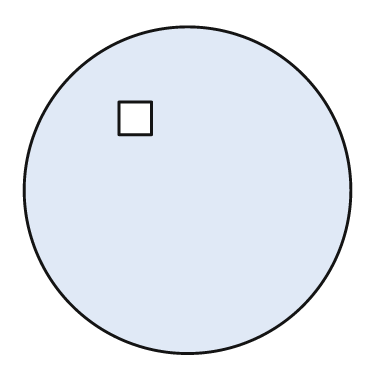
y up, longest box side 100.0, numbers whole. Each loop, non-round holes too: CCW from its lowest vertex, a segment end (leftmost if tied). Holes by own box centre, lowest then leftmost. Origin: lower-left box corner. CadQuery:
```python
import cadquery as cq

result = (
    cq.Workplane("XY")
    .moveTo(50.0, 50.0)
    .circle(50.0)
    .moveTo(29.0, 67.0)
    .lineTo(39.0, 67.0)
    .lineTo(39.0, 77.0)
    .lineTo(29.0, 77.0)
    .close()
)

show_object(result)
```